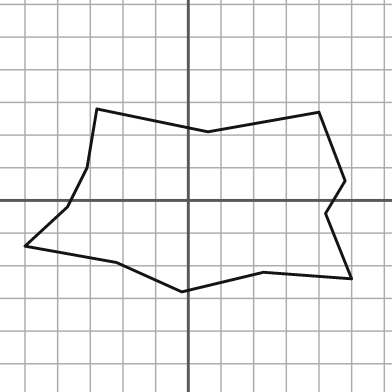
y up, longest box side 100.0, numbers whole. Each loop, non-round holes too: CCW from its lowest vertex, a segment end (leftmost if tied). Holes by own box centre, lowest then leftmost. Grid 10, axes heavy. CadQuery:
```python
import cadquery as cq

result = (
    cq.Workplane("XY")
    .moveTo(-2.0, -28.0)
    .lineTo(23.0, -22.0)
    .lineTo(50.0, -24.0)
    .lineTo(42.0, -4.0)
    .lineTo(48.0, 6.0)
    .lineTo(40.0, 27.0)
    .lineTo(6.0, 21.0)
    .lineTo(-28.0, 28.0)
    .lineTo(-31.0, 10.0)
    .lineTo(-37.0, -2.0)
    .lineTo(-50.0, -14.0)
    .lineTo(-22.0, -19.0)
    .close()
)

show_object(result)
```